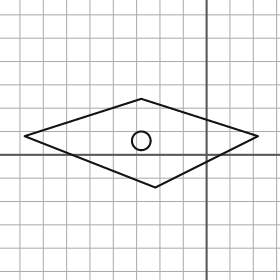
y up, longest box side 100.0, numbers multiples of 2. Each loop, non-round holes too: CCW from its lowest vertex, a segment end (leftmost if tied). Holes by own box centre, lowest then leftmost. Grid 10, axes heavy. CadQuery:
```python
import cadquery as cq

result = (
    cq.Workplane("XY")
    .moveTo(-22.0, -14.0)
    .lineTo(22.0, 8.0)
    .lineTo(-28.0, 24.0)
    .lineTo(-78.0, 8.0)
    .close()
    .moveTo(-28.0, 6.0)
    .circle(4.0)
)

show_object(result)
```